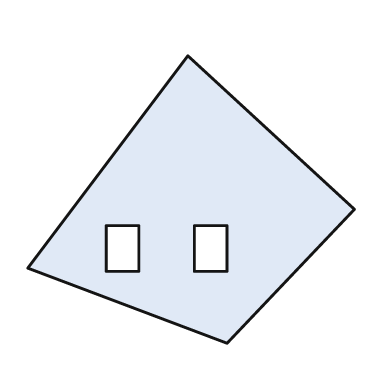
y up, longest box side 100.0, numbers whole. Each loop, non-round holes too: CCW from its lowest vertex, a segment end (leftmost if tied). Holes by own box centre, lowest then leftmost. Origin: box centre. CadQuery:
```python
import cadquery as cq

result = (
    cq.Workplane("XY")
    .moveTo(11.0, -44.0)
    .lineTo(50.0, -3.0)
    .lineTo(-1.0, 44.0)
    .lineTo(-50.0, -21.0)
    .close()
    .moveTo(-26.0, -22.0)
    .lineTo(-16.0, -22.0)
    .lineTo(-16.0, -8.0)
    .lineTo(-26.0, -8.0)
    .close()
    .moveTo(1.0, -22.0)
    .lineTo(11.0, -22.0)
    .lineTo(11.0, -8.0)
    .lineTo(1.0, -8.0)
    .close()
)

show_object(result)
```